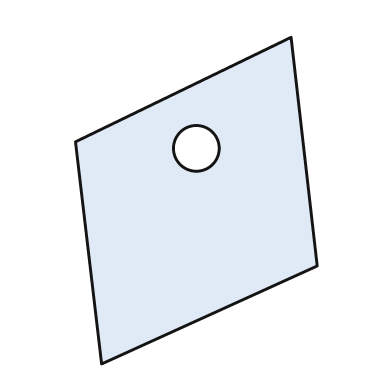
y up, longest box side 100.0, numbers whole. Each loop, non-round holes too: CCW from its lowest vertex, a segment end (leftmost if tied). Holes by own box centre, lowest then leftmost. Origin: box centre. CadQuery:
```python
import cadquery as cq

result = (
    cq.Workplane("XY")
    .moveTo(-29.0, -50.0)
    .lineTo(37.0, -20.0)
    .lineTo(29.0, 50.0)
    .lineTo(-37.0, 18.0)
    .close()
    .moveTo(0.0, 16.0)
    .circle(7.0)
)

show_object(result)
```